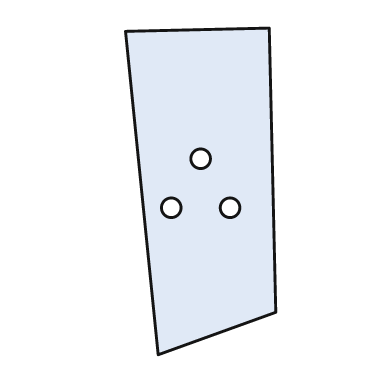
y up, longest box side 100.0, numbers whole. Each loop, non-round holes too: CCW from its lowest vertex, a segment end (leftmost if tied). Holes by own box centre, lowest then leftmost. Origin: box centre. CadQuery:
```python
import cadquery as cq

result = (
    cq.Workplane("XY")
    .moveTo(-13.0, -50.0)
    .lineTo(23.0, -37.0)
    .lineTo(21.0, 50.0)
    .lineTo(-23.0, 49.0)
    .close()
    .moveTo(-9.0, -5.0)
    .circle(3.0)
    .moveTo(9.0, -5.0)
    .circle(3.0)
    .moveTo(0.0, 10.0)
    .circle(3.0)
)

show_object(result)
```